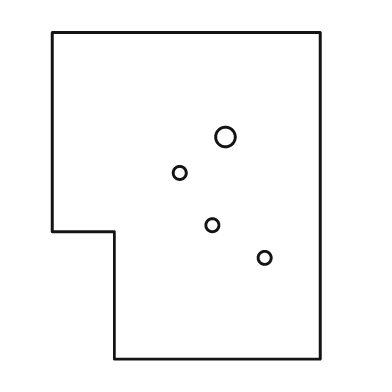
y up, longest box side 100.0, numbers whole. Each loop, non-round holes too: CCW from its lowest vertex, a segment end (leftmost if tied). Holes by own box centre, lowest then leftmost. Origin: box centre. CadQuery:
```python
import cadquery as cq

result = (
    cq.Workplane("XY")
    .moveTo(-22.0, -50.0)
    .lineTo(41.0, -50.0)
    .lineTo(41.0, 50.0)
    .lineTo(-41.0, 50.0)
    .lineTo(-41.0, -11.0)
    .lineTo(-22.0, -11.0)
    .close()
    .moveTo(24.0, -19.0)
    .circle(2.0)
    .moveTo(8.0, -9.0)
    .circle(2.0)
    .moveTo(-2.0, 7.0)
    .circle(2.0)
    .moveTo(12.0, 18.0)
    .circle(3.0)
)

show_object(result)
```